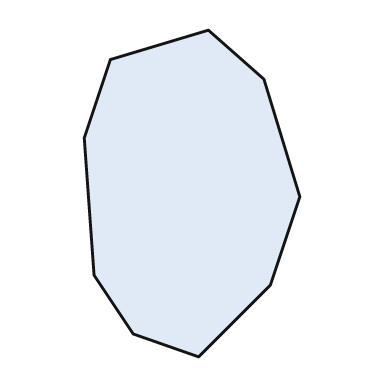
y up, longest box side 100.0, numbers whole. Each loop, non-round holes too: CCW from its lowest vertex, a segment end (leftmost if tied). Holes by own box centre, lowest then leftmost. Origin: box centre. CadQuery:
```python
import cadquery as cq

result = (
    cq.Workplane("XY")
    .moveTo(2.0, -50.0)
    .lineTo(24.0, -28.0)
    .lineTo(33.0, -1.0)
    .lineTo(22.0, 35.0)
    .lineTo(5.0, 50.0)
    .lineTo(-25.0, 41.0)
    .lineTo(-33.0, 17.0)
    .lineTo(-30.0, -25.0)
    .lineTo(-18.0, -43.0)
    .close()
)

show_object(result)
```